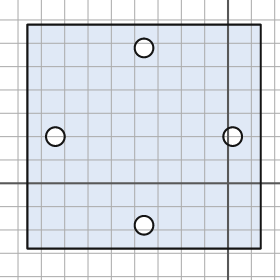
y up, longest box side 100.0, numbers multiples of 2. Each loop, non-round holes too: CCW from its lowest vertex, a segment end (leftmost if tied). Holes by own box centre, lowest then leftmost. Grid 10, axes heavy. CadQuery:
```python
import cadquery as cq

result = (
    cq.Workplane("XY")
    .moveTo(-86.0, -28.0)
    .lineTo(14.0, -28.0)
    .lineTo(14.0, 68.0)
    .lineTo(-86.0, 68.0)
    .close()
    .moveTo(-36.0, -18.0)
    .circle(4.0)
    .moveTo(-74.0, 20.0)
    .circle(4.0)
    .moveTo(2.0, 20.0)
    .circle(4.0)
    .moveTo(-36.0, 58.0)
    .circle(4.0)
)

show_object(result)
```